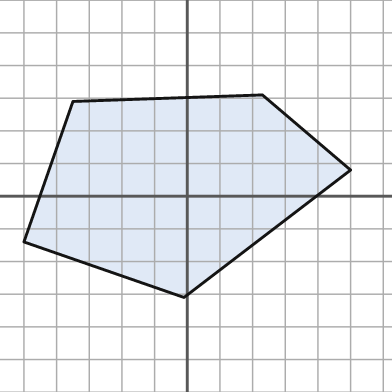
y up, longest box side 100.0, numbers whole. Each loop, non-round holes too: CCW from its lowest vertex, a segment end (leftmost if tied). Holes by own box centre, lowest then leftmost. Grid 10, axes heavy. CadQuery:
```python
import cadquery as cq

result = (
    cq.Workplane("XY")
    .moveTo(-1.0, -31.0)
    .lineTo(50.0, 8.0)
    .lineTo(23.0, 31.0)
    .lineTo(-35.0, 29.0)
    .lineTo(-50.0, -14.0)
    .close()
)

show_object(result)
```